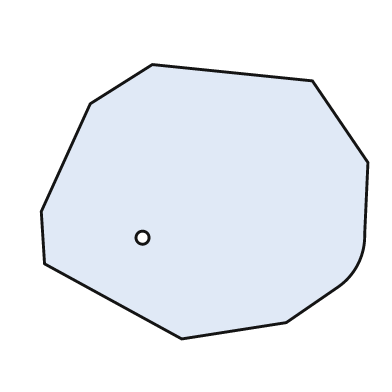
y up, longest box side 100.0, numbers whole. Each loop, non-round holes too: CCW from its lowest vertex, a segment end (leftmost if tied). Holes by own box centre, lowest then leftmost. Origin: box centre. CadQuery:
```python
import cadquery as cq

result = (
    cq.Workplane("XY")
    .moveTo(-7.0, -42.0)
    .lineTo(25.0, -37.0)
    .lineTo(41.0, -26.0)
    .threePointArc((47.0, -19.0), (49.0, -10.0))
    .lineTo(50.0, 12.0)
    .lineTo(33.0, 37.0)
    .lineTo(-16.0, 42.0)
    .lineTo(-35.0, 30.0)
    .lineTo(-50.0, -3.0)
    .lineTo(-49.0, -19.0)
    .close()
    .moveTo(-19.0, -11.0)
    .circle(2.0)
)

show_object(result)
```